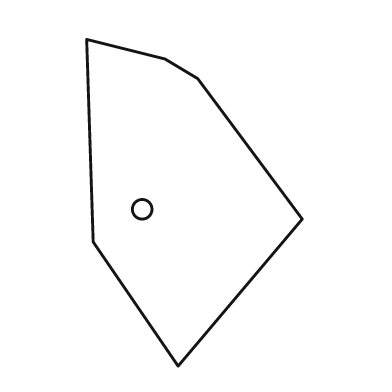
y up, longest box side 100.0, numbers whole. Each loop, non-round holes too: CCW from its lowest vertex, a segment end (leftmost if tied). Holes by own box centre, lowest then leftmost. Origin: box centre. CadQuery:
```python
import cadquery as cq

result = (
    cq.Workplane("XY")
    .moveTo(-5.0, -50.0)
    .lineTo(33.0, -5.0)
    .lineTo(1.0, 38.0)
    .lineTo(-9.0, 44.0)
    .lineTo(-33.0, 50.0)
    .lineTo(-31.0, -12.0)
    .close()
    .moveTo(-16.0, -2.0)
    .circle(3.0)
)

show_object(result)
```